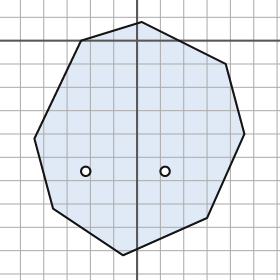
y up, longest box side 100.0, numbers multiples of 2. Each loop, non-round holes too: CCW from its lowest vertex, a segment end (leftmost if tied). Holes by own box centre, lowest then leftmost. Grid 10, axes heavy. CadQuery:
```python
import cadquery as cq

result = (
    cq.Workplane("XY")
    .moveTo(-6.0, -92.0)
    .lineTo(30.0, -76.0)
    .lineTo(46.0, -40.0)
    .lineTo(38.0, -10.0)
    .lineTo(2.0, 8.0)
    .lineTo(-24.0, 0.0)
    .lineTo(-44.0, -42.0)
    .lineTo(-36.0, -72.0)
    .close()
    .moveTo(-22.0, -56.0)
    .circle(2.0)
    .moveTo(12.0, -56.0)
    .circle(2.0)
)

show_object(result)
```